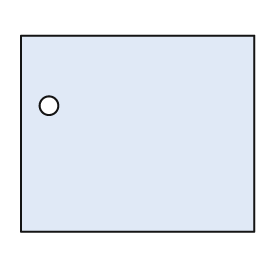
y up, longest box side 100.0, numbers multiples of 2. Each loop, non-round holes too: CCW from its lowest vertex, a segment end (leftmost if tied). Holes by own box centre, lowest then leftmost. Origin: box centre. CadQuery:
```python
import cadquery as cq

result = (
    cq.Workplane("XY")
    .moveTo(-50.0, -42.0)
    .lineTo(50.0, -42.0)
    .lineTo(50.0, 42.0)
    .lineTo(-50.0, 42.0)
    .close()
    .moveTo(-38.0, 12.0)
    .circle(4.0)
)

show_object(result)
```